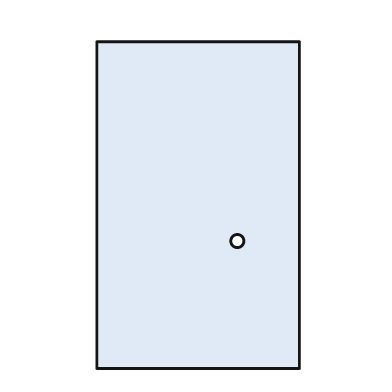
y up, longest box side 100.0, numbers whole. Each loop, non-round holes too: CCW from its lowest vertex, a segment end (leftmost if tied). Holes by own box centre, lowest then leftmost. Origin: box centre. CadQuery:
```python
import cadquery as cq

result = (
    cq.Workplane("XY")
    .moveTo(-31.0, -50.0)
    .lineTo(31.0, -50.0)
    .lineTo(31.0, 50.0)
    .lineTo(-31.0, 50.0)
    .close()
    .moveTo(12.0, -11.0)
    .circle(2.0)
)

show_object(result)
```